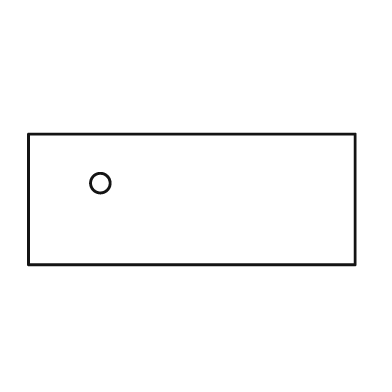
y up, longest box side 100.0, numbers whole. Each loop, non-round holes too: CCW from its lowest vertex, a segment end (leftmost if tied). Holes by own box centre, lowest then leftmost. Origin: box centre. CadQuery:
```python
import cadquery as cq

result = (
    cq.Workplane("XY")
    .moveTo(-50.0, -20.0)
    .lineTo(50.0, -20.0)
    .lineTo(50.0, 20.0)
    .lineTo(-50.0, 20.0)
    .close()
    .moveTo(-28.0, 5.0)
    .circle(3.0)
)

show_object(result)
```